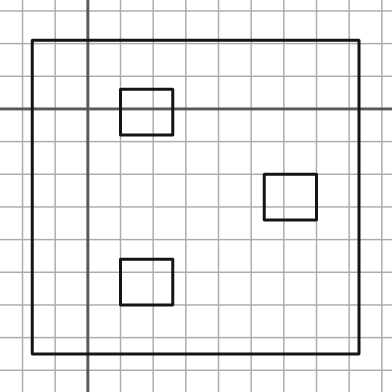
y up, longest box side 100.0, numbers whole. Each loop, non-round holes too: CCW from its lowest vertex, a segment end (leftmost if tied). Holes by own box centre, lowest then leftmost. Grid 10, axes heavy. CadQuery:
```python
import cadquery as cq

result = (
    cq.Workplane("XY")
    .moveTo(-17.0, -75.0)
    .lineTo(83.0, -75.0)
    .lineTo(83.0, 21.0)
    .lineTo(-17.0, 21.0)
    .close()
    .moveTo(10.0, -60.0)
    .lineTo(26.0, -60.0)
    .lineTo(26.0, -46.0)
    .lineTo(10.0, -46.0)
    .close()
    .moveTo(54.0, -34.0)
    .lineTo(70.0, -34.0)
    .lineTo(70.0, -20.0)
    .lineTo(54.0, -20.0)
    .close()
    .moveTo(10.0, -8.0)
    .lineTo(26.0, -8.0)
    .lineTo(26.0, 6.0)
    .lineTo(10.0, 6.0)
    .close()
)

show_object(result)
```